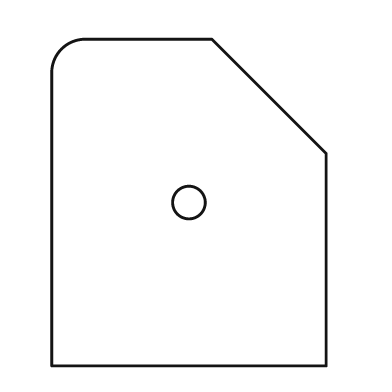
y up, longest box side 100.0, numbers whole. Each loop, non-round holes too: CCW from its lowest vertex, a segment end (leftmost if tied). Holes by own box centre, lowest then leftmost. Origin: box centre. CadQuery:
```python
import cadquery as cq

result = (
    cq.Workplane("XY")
    .moveTo(-42.0, -50.0)
    .lineTo(42.0, -50.0)
    .lineTo(42.0, 15.0)
    .lineTo(7.0, 50.0)
    .lineTo(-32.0, 50.0)
    .threePointArc((-39.0, 47.0), (-42.0, 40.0))
    .close()
    .moveTo(0.0, 0.0)
    .circle(5.0)
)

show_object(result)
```